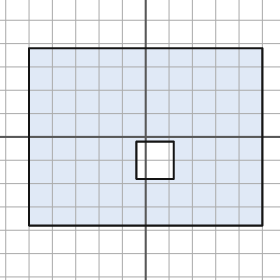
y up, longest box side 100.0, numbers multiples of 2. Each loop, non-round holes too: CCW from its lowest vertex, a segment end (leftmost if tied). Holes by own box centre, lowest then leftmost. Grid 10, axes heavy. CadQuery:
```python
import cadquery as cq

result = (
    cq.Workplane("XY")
    .moveTo(-50.0, -38.0)
    .lineTo(50.0, -38.0)
    .lineTo(50.0, 38.0)
    .lineTo(-50.0, 38.0)
    .close()
    .moveTo(-4.0, -18.0)
    .lineTo(12.0, -18.0)
    .lineTo(12.0, -2.0)
    .lineTo(-4.0, -2.0)
    .close()
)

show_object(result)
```